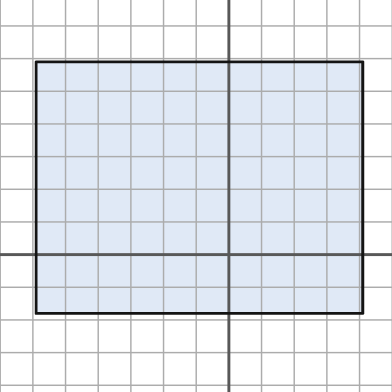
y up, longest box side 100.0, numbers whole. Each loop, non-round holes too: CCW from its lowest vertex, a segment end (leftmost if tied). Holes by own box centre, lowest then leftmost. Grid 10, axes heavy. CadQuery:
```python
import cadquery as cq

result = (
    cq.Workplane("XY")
    .moveTo(-59.0, -18.0)
    .lineTo(41.0, -18.0)
    .lineTo(41.0, 59.0)
    .lineTo(-59.0, 59.0)
    .close()
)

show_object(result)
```